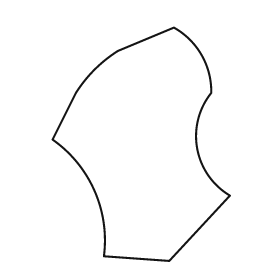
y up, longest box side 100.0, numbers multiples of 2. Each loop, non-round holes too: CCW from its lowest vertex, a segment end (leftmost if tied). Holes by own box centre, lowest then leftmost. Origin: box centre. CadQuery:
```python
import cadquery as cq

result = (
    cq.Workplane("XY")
    .moveTo(12.0, -50.0)
    .lineTo(38.0, -22.0)
    .threePointArc((24.0, -2.0), (30.0, 22.0))
    .threePointArc((26.0, 38.0), (14.0, 50.0))
    .lineTo(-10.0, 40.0)
    .threePointArc((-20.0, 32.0), (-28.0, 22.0))
    .lineTo(-38.0, 2.0)
    .threePointArc((-20.0, -20.0), (-16.0, -48.0))
    .close()
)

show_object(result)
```